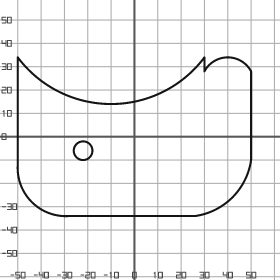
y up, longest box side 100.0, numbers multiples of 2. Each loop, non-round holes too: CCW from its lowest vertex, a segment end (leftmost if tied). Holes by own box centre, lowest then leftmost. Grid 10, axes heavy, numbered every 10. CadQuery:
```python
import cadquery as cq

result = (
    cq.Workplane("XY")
    .moveTo(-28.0, -34.0)
    .lineTo(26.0, -34.0)
    .threePointArc((42.0, -26.0), (50.0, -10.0))
    .lineTo(50.0, 28.0)
    .threePointArc((40.0, 34.0), (30.0, 28.0))
    .lineTo(30.0, 34.0)
    .threePointArc((-10.0, 14.0), (-50.0, 34.0))
    .lineTo(-50.0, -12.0)
    .threePointArc((-44.0, -28.0), (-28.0, -34.0))
    .close()
    .moveTo(-22.0, -6.0)
    .circle(4.0)
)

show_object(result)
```